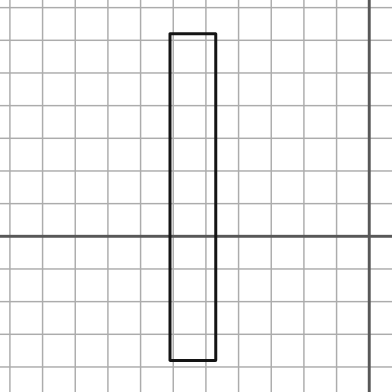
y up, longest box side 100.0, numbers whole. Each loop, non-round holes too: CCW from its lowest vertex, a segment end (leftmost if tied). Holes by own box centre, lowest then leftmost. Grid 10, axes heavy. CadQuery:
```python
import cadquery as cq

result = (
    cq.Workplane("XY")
    .moveTo(-61.0, -38.0)
    .lineTo(-47.0, -38.0)
    .lineTo(-47.0, 62.0)
    .lineTo(-61.0, 62.0)
    .close()
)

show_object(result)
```